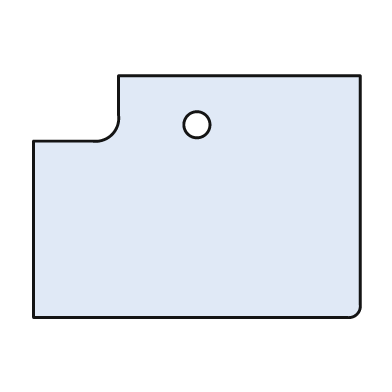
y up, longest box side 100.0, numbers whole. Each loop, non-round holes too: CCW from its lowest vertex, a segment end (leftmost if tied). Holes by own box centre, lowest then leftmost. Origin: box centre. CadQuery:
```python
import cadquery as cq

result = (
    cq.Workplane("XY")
    .moveTo(-50.0, -37.0)
    .lineTo(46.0, -37.0)
    .threePointArc((49.0, -36.0), (50.0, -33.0))
    .lineTo(50.0, 37.0)
    .lineTo(-24.0, 37.0)
    .lineTo(-24.0, 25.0)
    .threePointArc((-26.0, 19.0), (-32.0, 17.0))
    .lineTo(-50.0, 17.0)
    .close()
    .moveTo(0.0, 22.0)
    .circle(4.0)
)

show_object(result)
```